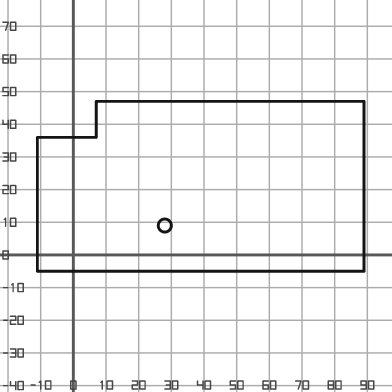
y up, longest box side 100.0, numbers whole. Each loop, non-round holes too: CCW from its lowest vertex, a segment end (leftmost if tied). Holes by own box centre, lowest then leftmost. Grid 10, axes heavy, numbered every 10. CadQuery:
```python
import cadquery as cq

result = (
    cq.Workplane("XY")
    .moveTo(-11.0, -5.0)
    .lineTo(89.0, -5.0)
    .lineTo(89.0, 47.0)
    .lineTo(7.0, 47.0)
    .lineTo(7.0, 36.0)
    .lineTo(-11.0, 36.0)
    .close()
    .moveTo(28.0, 9.0)
    .circle(2.0)
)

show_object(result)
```